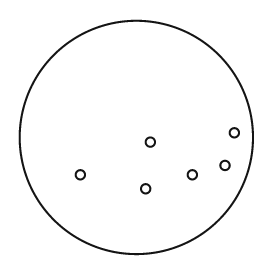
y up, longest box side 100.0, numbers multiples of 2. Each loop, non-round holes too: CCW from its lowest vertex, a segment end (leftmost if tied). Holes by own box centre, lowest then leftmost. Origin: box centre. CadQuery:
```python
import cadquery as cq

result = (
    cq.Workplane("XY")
    .moveTo(0.0, 0.0)
    .circle(50.0)
    .moveTo(4.0, -22.0)
    .circle(2.0)
    .moveTo(-24.0, -16.0)
    .circle(2.0)
    .moveTo(24.0, -16.0)
    .circle(2.0)
    .moveTo(38.0, -12.0)
    .circle(2.0)
    .moveTo(6.0, -2.0)
    .circle(2.0)
    .moveTo(42.0, 2.0)
    .circle(2.0)
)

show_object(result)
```